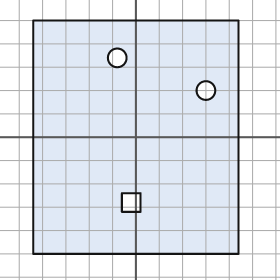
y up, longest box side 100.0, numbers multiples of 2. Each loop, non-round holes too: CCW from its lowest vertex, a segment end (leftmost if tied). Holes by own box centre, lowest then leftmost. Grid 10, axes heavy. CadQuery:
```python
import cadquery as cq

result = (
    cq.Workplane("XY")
    .moveTo(-44.0, -50.0)
    .lineTo(44.0, -50.0)
    .lineTo(44.0, 50.0)
    .lineTo(-44.0, 50.0)
    .close()
    .moveTo(-6.0, -32.0)
    .lineTo(2.0, -32.0)
    .lineTo(2.0, -24.0)
    .lineTo(-6.0, -24.0)
    .close()
    .moveTo(30.0, 20.0)
    .circle(4.0)
    .moveTo(-8.0, 34.0)
    .circle(4.0)
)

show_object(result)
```